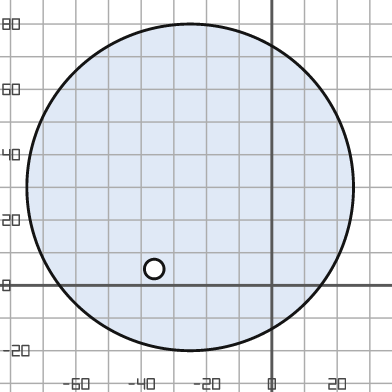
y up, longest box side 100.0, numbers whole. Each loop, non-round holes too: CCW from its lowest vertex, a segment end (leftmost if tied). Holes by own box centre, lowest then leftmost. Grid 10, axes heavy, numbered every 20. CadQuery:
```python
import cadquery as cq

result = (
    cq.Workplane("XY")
    .moveTo(-25.0, 30.0)
    .circle(50.0)
    .moveTo(-36.0, 5.0)
    .circle(3.0)
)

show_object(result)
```